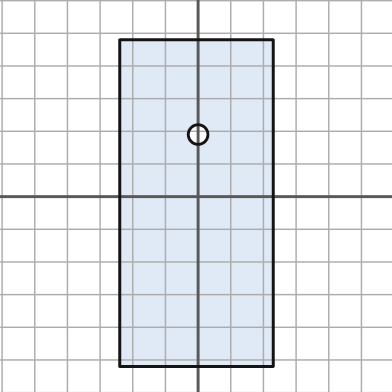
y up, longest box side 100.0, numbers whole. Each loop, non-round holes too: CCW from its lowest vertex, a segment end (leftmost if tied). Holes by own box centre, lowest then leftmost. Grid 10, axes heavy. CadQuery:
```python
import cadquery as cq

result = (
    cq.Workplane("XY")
    .moveTo(-24.0, -52.0)
    .lineTo(23.0, -52.0)
    .lineTo(23.0, 48.0)
    .lineTo(-24.0, 48.0)
    .close()
    .moveTo(0.0, 19.0)
    .circle(3.0)
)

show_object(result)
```